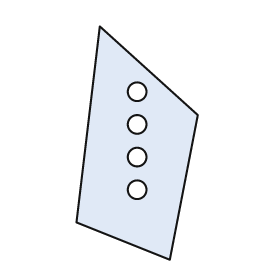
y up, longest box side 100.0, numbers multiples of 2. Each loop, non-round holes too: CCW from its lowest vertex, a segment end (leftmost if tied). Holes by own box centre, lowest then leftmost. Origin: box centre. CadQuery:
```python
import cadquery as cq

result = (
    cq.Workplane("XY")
    .moveTo(14.0, -50.0)
    .lineTo(26.0, 12.0)
    .lineTo(-16.0, 50.0)
    .lineTo(-26.0, -34.0)
    .close()
    .moveTo(0.0, -20.0)
    .circle(4.0)
    .moveTo(0.0, -6.0)
    .circle(4.0)
    .moveTo(0.0, 8.0)
    .circle(4.0)
    .moveTo(0.0, 22.0)
    .circle(4.0)
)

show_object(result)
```